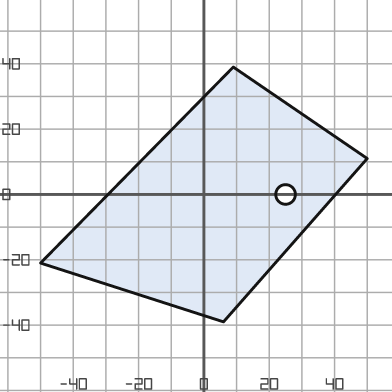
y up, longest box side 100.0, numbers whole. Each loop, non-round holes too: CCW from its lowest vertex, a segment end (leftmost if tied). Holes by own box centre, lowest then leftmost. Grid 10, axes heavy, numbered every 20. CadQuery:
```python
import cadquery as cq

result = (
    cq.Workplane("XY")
    .moveTo(6.0, -39.0)
    .lineTo(50.0, 11.0)
    .lineTo(9.0, 39.0)
    .lineTo(-50.0, -21.0)
    .close()
    .moveTo(25.0, 0.0)
    .circle(3.0)
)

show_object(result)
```